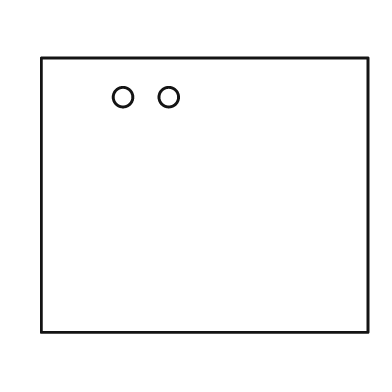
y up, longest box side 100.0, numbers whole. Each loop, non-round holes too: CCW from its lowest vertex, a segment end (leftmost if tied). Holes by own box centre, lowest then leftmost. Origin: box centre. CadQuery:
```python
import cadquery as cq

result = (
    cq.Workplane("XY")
    .moveTo(-50.0, -42.0)
    .lineTo(50.0, -42.0)
    .lineTo(50.0, 42.0)
    .lineTo(-50.0, 42.0)
    .close()
    .moveTo(-25.0, 30.0)
    .circle(3.0)
    .moveTo(-11.0, 30.0)
    .circle(3.0)
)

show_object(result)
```